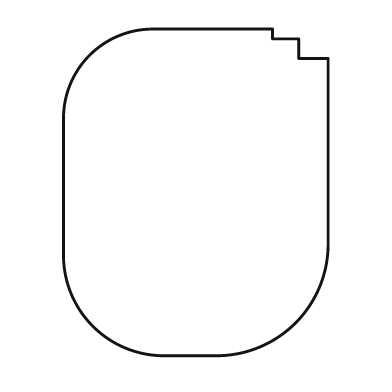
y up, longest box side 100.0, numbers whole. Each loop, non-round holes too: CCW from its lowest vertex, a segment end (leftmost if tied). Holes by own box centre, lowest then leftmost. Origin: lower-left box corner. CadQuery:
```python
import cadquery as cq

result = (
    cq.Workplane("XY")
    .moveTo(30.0, 0.0)
    .lineTo(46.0, 0.0)
    .threePointArc((71.0, 10.0), (81.0, 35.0))
    .lineTo(81.0, 91.0)
    .lineTo(72.0, 91.0)
    .lineTo(72.0, 97.0)
    .lineTo(64.0, 97.0)
    .lineTo(64.0, 100.0)
    .lineTo(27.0, 100.0)
    .threePointArc((8.0, 92.0), (0.0, 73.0))
    .lineTo(0.0, 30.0)
    .threePointArc((9.0, 9.0), (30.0, 0.0))
    .close()
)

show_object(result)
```